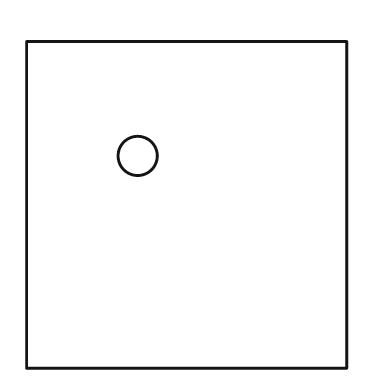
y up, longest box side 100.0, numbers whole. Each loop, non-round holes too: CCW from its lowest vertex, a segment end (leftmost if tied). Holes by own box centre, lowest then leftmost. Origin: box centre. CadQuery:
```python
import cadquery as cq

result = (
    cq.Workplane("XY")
    .moveTo(-49.0, -50.0)
    .lineTo(49.0, -50.0)
    .lineTo(49.0, 50.0)
    .lineTo(-49.0, 50.0)
    .close()
    .moveTo(-15.0, 15.0)
    .circle(6.0)
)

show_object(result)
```